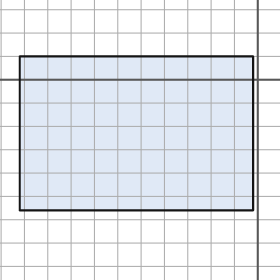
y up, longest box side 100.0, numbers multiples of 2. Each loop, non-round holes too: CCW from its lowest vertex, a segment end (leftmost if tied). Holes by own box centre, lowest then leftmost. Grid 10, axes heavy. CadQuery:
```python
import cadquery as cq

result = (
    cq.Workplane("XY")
    .moveTo(-102.0, -56.0)
    .lineTo(-2.0, -56.0)
    .lineTo(-2.0, 10.0)
    .lineTo(-102.0, 10.0)
    .close()
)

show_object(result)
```